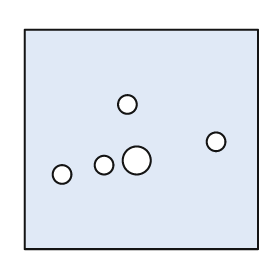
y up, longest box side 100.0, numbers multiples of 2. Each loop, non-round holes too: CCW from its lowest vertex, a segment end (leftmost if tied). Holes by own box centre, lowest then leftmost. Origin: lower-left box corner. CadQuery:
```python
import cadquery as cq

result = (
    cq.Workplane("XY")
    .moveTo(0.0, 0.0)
    .lineTo(100.0, 0.0)
    .lineTo(100.0, 94.0)
    .lineTo(0.0, 94.0)
    .close()
    .moveTo(16.0, 32.0)
    .circle(4.0)
    .moveTo(34.0, 36.0)
    .circle(4.0)
    .moveTo(48.0, 38.0)
    .circle(6.0)
    .moveTo(82.0, 46.0)
    .circle(4.0)
    .moveTo(44.0, 62.0)
    .circle(4.0)
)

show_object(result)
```